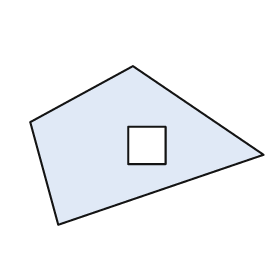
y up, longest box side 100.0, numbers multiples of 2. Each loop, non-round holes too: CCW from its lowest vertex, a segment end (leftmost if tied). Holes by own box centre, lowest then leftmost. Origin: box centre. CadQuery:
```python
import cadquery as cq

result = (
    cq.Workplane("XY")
    .moveTo(-38.0, -34.0)
    .lineTo(50.0, -4.0)
    .lineTo(-6.0, 34.0)
    .lineTo(-50.0, 10.0)
    .close()
    .moveTo(-8.0, -8.0)
    .lineTo(8.0, -8.0)
    .lineTo(8.0, 8.0)
    .lineTo(-8.0, 8.0)
    .close()
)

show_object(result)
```